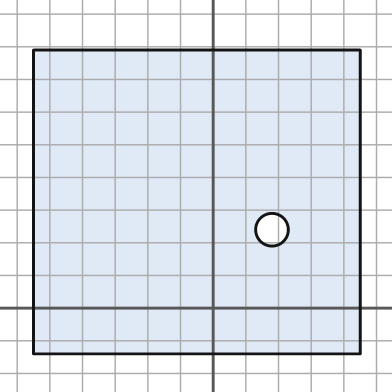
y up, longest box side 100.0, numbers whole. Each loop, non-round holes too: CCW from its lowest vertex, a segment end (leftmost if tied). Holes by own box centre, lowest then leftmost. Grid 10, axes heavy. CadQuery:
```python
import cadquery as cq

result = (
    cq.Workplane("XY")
    .moveTo(-55.0, -14.0)
    .lineTo(45.0, -14.0)
    .lineTo(45.0, 79.0)
    .lineTo(-55.0, 79.0)
    .close()
    .moveTo(18.0, 24.0)
    .circle(5.0)
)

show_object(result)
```